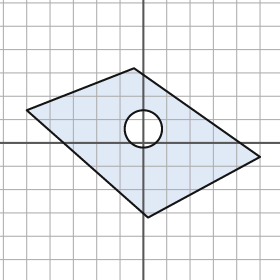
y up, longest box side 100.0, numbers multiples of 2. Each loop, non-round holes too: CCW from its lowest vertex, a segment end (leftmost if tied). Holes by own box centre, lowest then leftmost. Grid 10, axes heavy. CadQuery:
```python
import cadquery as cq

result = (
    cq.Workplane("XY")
    .moveTo(2.0, -32.0)
    .lineTo(50.0, -6.0)
    .lineTo(-4.0, 32.0)
    .lineTo(-50.0, 14.0)
    .close()
    .moveTo(0.0, 6.0)
    .circle(8.0)
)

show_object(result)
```